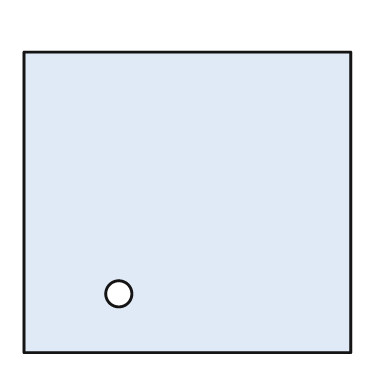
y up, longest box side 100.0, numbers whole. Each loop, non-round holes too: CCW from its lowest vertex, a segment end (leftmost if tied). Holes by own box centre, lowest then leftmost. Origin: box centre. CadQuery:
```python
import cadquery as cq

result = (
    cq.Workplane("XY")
    .moveTo(-50.0, -46.0)
    .lineTo(50.0, -46.0)
    .lineTo(50.0, 46.0)
    .lineTo(-50.0, 46.0)
    .close()
    .moveTo(-21.0, -28.0)
    .circle(4.0)
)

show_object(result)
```